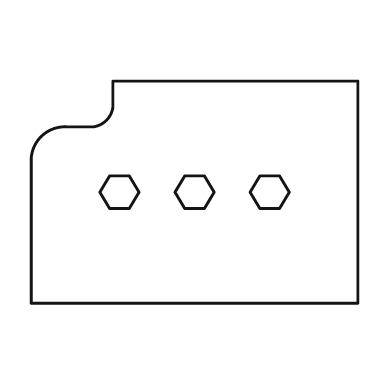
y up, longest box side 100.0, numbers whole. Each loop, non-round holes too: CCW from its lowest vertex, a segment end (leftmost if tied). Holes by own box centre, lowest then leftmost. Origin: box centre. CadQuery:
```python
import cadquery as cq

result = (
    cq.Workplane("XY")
    .moveTo(-50.0, -34.0)
    .lineTo(50.0, -34.0)
    .lineTo(50.0, 34.0)
    .lineTo(-25.0, 34.0)
    .lineTo(-25.0, 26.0)
    .threePointArc((-27.0, 22.0), (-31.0, 20.0))
    .lineTo(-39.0, 20.0)
    .threePointArc((-47.0, 17.0), (-50.0, 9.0))
    .close()
    .moveTo(-26.0, -5.0)
    .lineTo(-20.0, -5.0)
    .lineTo(-17.0, 0.0)
    .lineTo(-20.0, 5.0)
    .lineTo(-26.0, 5.0)
    .lineTo(-29.0, 0.0)
    .close()
    .moveTo(-3.0, -5.0)
    .lineTo(3.0, -5.0)
    .lineTo(6.0, 0.0)
    .lineTo(3.0, 5.0)
    .lineTo(-3.0, 5.0)
    .lineTo(-6.0, 0.0)
    .close()
    .moveTo(20.0, -5.0)
    .lineTo(26.0, -5.0)
    .lineTo(29.0, 0.0)
    .lineTo(26.0, 5.0)
    .lineTo(20.0, 5.0)
    .lineTo(17.0, 0.0)
    .close()
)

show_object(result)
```